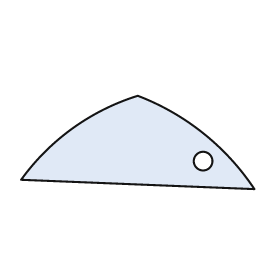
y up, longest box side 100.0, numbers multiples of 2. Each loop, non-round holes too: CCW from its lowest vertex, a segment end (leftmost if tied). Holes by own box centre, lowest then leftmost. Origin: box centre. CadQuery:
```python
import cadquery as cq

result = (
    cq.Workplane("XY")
    .moveTo(50.0, -20.0)
    .threePointArc((28.0, 4.0), (0.0, 20.0))
    .threePointArc((-28.0, 6.0), (-50.0, -16.0))
    .close()
    .moveTo(28.0, -8.0)
    .circle(4.0)
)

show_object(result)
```